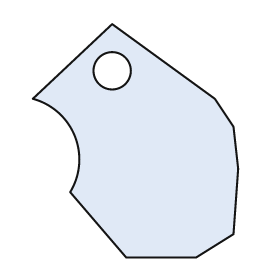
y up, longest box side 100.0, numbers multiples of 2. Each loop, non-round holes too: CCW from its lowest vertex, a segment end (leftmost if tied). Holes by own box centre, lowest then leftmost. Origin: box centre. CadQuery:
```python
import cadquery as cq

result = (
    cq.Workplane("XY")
    .moveTo(-4.0, -50.0)
    .lineTo(26.0, -50.0)
    .lineTo(42.0, -40.0)
    .lineTo(44.0, -12.0)
    .lineTo(42.0, 6.0)
    .lineTo(34.0, 18.0)
    .lineTo(-10.0, 50.0)
    .lineTo(-44.0, 18.0)
    .threePointArc((-26.0, 2.0), (-28.0, -22.0))
    .close()
    .moveTo(-10.0, 30.0)
    .circle(8.0)
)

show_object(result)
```